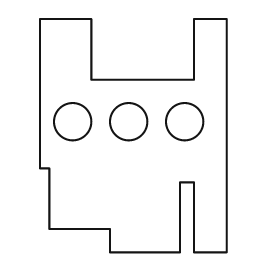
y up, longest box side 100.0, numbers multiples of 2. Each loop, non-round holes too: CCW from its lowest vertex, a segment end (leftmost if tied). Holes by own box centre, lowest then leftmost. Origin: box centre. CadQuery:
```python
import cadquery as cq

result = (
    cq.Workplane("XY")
    .moveTo(-10.0, -50.0)
    .lineTo(20.0, -50.0)
    .lineTo(20.0, -20.0)
    .lineTo(26.0, -20.0)
    .lineTo(26.0, -50.0)
    .lineTo(40.0, -50.0)
    .lineTo(40.0, 50.0)
    .lineTo(26.0, 50.0)
    .lineTo(26.0, 24.0)
    .lineTo(-18.0, 24.0)
    .lineTo(-18.0, 50.0)
    .lineTo(-40.0, 50.0)
    .lineTo(-40.0, -14.0)
    .lineTo(-36.0, -14.0)
    .lineTo(-36.0, -40.0)
    .lineTo(-10.0, -40.0)
    .close()
    .moveTo(-26.0, 6.0)
    .circle(8.0)
    .moveTo(-2.0, 6.0)
    .circle(8.0)
    .moveTo(22.0, 6.0)
    .circle(8.0)
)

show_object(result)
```